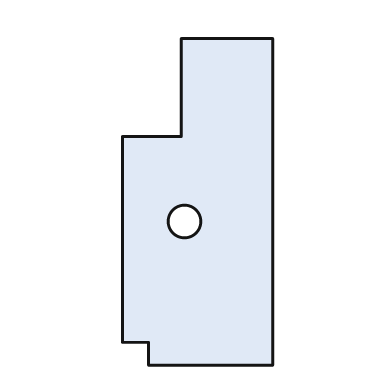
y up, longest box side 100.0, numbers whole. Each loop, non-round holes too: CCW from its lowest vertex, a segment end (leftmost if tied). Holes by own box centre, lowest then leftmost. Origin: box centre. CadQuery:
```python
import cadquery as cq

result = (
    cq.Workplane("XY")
    .moveTo(-15.0, -50.0)
    .lineTo(23.0, -50.0)
    .lineTo(23.0, 50.0)
    .lineTo(-5.0, 50.0)
    .lineTo(-5.0, 20.0)
    .lineTo(-23.0, 20.0)
    .lineTo(-23.0, -43.0)
    .lineTo(-15.0, -43.0)
    .close()
    .moveTo(-4.0, -6.0)
    .circle(5.0)
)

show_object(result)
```